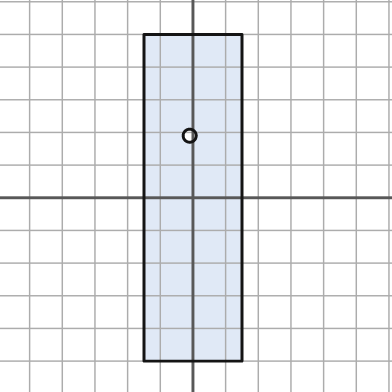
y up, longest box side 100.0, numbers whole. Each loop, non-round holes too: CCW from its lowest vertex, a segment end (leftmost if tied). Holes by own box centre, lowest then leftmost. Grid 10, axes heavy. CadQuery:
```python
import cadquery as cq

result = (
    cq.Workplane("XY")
    .moveTo(-15.0, -50.0)
    .lineTo(15.0, -50.0)
    .lineTo(15.0, 50.0)
    .lineTo(-15.0, 50.0)
    .close()
    .moveTo(-1.0, 19.0)
    .circle(2.0)
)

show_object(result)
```